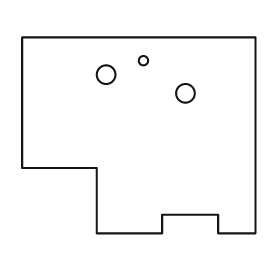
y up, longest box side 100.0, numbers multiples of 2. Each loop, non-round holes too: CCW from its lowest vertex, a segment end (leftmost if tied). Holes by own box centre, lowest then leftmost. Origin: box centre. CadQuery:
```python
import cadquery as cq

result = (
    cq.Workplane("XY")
    .moveTo(-18.0, -42.0)
    .lineTo(10.0, -42.0)
    .lineTo(10.0, -34.0)
    .lineTo(34.0, -34.0)
    .lineTo(34.0, -42.0)
    .lineTo(50.0, -42.0)
    .lineTo(50.0, 42.0)
    .lineTo(-50.0, 42.0)
    .lineTo(-50.0, -14.0)
    .lineTo(-18.0, -14.0)
    .close()
    .moveTo(20.0, 18.0)
    .circle(4.0)
    .moveTo(-14.0, 26.0)
    .circle(4.0)
    .moveTo(2.0, 32.0)
    .circle(2.0)
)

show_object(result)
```